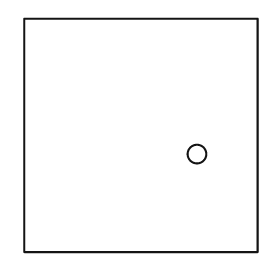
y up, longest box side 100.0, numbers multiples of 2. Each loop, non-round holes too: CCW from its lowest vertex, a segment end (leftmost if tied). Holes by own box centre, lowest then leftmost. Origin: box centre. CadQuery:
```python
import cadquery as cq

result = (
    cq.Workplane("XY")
    .moveTo(-50.0, -50.0)
    .lineTo(50.0, -50.0)
    .lineTo(50.0, 50.0)
    .lineTo(-50.0, 50.0)
    .close()
    .moveTo(24.0, -8.0)
    .circle(4.0)
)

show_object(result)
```